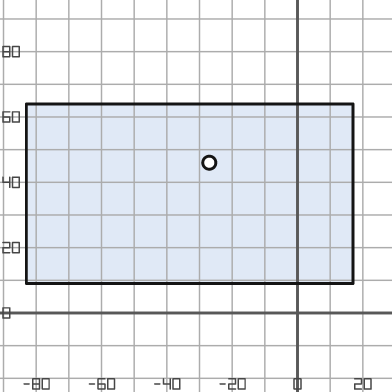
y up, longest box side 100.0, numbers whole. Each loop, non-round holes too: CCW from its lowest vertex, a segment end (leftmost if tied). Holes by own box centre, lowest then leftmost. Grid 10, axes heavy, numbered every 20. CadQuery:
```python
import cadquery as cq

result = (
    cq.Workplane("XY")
    .moveTo(-83.0, 9.0)
    .lineTo(17.0, 9.0)
    .lineTo(17.0, 64.0)
    .lineTo(-83.0, 64.0)
    .close()
    .moveTo(-27.0, 46.0)
    .circle(2.0)
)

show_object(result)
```